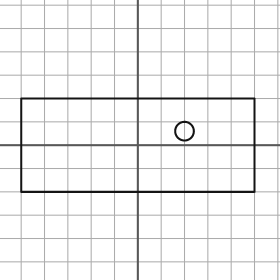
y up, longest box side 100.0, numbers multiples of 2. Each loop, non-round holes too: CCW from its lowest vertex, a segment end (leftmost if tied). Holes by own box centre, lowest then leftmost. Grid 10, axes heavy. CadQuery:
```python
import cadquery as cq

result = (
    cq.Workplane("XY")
    .moveTo(-50.0, -20.0)
    .lineTo(50.0, -20.0)
    .lineTo(50.0, 20.0)
    .lineTo(-50.0, 20.0)
    .close()
    .moveTo(20.0, 6.0)
    .circle(4.0)
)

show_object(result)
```